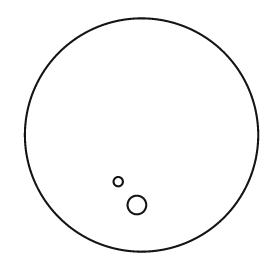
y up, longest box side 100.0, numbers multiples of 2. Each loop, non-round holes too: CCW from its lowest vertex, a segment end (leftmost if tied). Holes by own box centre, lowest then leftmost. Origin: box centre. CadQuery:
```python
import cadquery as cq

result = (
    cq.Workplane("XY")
    .moveTo(0.0, 0.0)
    .circle(50.0)
    .moveTo(-2.0, -30.0)
    .circle(4.0)
    .moveTo(-10.0, -20.0)
    .circle(2.0)
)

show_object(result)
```